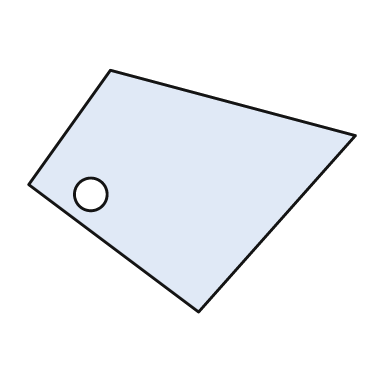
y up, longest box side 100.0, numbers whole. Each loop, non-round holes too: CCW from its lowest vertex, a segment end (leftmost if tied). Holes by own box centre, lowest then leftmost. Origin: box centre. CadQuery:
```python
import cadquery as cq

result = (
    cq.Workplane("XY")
    .moveTo(2.0, -37.0)
    .lineTo(50.0, 17.0)
    .lineTo(-25.0, 37.0)
    .lineTo(-50.0, 2.0)
    .close()
    .moveTo(-31.0, -1.0)
    .circle(5.0)
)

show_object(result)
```